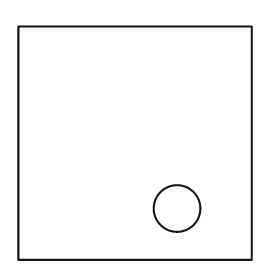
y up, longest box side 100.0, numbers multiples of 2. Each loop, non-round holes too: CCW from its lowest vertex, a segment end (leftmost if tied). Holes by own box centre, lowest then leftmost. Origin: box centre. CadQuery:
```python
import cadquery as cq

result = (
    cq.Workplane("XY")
    .moveTo(-50.0, -50.0)
    .lineTo(50.0, -50.0)
    .lineTo(50.0, 50.0)
    .lineTo(-50.0, 50.0)
    .close()
    .moveTo(18.0, -28.0)
    .circle(10.0)
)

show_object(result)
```